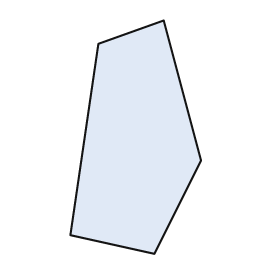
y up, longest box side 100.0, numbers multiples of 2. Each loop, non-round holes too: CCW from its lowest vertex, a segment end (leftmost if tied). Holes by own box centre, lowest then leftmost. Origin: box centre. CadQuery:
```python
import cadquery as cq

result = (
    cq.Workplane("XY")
    .moveTo(8.0, -50.0)
    .lineTo(28.0, -10.0)
    .lineTo(12.0, 50.0)
    .lineTo(-16.0, 40.0)
    .lineTo(-28.0, -42.0)
    .close()
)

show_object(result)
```